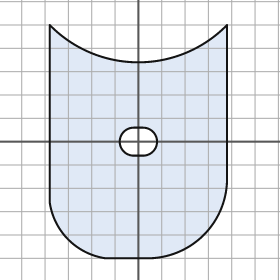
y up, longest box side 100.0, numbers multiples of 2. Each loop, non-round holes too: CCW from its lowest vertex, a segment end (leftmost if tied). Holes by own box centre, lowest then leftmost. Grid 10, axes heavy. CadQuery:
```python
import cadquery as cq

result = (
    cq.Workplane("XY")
    .moveTo(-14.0, -50.0)
    .lineTo(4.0, -50.0)
    .threePointArc((28.0, -40.0), (38.0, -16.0))
    .lineTo(38.0, 50.0)
    .threePointArc((0.0, 34.0), (-38.0, 50.0))
    .lineTo(-38.0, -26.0)
    .threePointArc((-30.0, -42.0), (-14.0, -50.0))
    .close()
    .moveTo(-2.0, -6.0)
    .lineTo(2.0, -6.0)
    .threePointArc((8.0, 0.0), (2.0, 6.0))
    .lineTo(-2.0, 6.0)
    .threePointArc((-8.0, 0.0), (-2.0, -6.0))
    .close()
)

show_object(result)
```